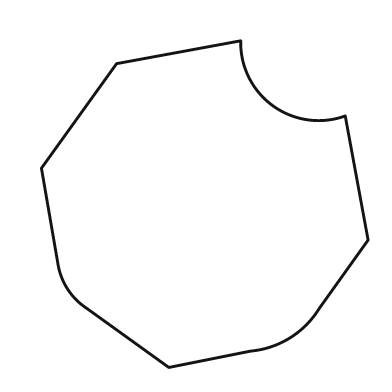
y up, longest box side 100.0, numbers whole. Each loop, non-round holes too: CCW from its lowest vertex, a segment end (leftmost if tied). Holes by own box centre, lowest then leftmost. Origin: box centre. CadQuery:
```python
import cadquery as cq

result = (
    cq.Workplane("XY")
    .moveTo(-11.0, -50.0)
    .lineTo(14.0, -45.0)
    .threePointArc((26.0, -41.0), (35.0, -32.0))
    .lineTo(50.0, -11.0)
    .lineTo(43.0, 27.0)
    .threePointArc((21.0, 30.0), (11.0, 50.0))
    .lineTo(-27.0, 43.0)
    .lineTo(-50.0, 11.0)
    .lineTo(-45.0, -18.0)
    .threePointArc((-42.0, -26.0), (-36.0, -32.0))
    .close()
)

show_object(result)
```